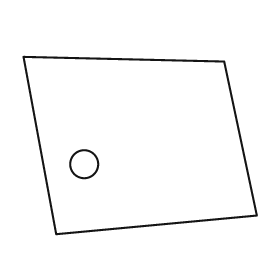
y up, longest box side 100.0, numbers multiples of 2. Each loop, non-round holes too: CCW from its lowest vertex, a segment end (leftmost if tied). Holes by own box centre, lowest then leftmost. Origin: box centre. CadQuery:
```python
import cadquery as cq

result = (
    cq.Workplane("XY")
    .moveTo(-36.0, -38.0)
    .lineTo(50.0, -30.0)
    .lineTo(36.0, 36.0)
    .lineTo(-50.0, 38.0)
    .close()
    .moveTo(-24.0, -8.0)
    .circle(6.0)
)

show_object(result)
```